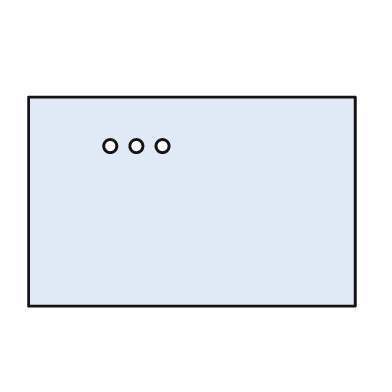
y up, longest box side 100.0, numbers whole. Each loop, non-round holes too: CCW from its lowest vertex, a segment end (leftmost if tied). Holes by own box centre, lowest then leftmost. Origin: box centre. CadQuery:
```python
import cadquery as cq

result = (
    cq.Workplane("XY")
    .moveTo(-50.0, -32.0)
    .lineTo(50.0, -32.0)
    .lineTo(50.0, 32.0)
    .lineTo(-50.0, 32.0)
    .close()
    .moveTo(-25.0, 17.0)
    .circle(2.0)
    .moveTo(-17.0, 17.0)
    .circle(2.0)
    .moveTo(-9.0, 17.0)
    .circle(2.0)
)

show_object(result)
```